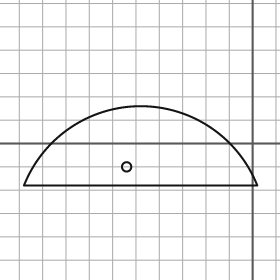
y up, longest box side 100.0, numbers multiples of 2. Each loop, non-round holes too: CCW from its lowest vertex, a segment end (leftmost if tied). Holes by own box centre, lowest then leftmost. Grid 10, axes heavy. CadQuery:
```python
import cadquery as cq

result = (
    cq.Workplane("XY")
    .moveTo(-98.0, -18.0)
    .lineTo(2.0, -18.0)
    .threePointArc((-48.0, 16.0), (-98.0, -18.0))
    .close()
    .moveTo(-54.0, -10.0)
    .circle(2.0)
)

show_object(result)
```